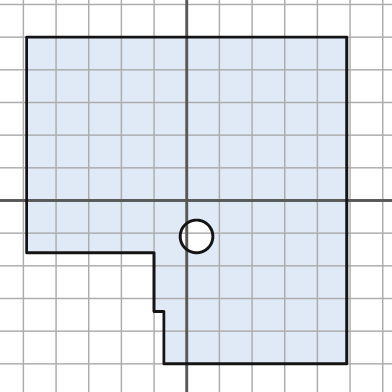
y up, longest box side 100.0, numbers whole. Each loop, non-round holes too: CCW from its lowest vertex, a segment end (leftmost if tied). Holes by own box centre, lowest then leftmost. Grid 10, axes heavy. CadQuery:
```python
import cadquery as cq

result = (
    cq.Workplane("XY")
    .moveTo(-7.0, -50.0)
    .lineTo(49.0, -50.0)
    .lineTo(49.0, 50.0)
    .lineTo(-49.0, 50.0)
    .lineTo(-49.0, -16.0)
    .lineTo(-10.0, -16.0)
    .lineTo(-10.0, -34.0)
    .lineTo(-7.0, -34.0)
    .close()
    .moveTo(3.0, -11.0)
    .circle(5.0)
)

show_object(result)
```